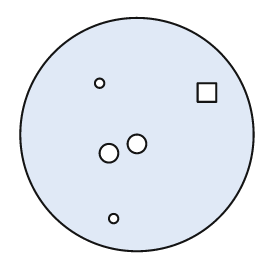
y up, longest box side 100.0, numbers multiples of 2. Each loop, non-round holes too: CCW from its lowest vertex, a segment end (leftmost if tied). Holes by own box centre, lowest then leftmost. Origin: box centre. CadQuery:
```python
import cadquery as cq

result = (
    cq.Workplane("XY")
    .moveTo(0.0, 0.0)
    .circle(50.0)
    .moveTo(-10.0, -36.0)
    .circle(2.0)
    .moveTo(-12.0, -8.0)
    .circle(4.0)
    .moveTo(0.0, -4.0)
    .circle(4.0)
    .moveTo(26.0, 14.0)
    .lineTo(34.0, 14.0)
    .lineTo(34.0, 22.0)
    .lineTo(26.0, 22.0)
    .close()
    .moveTo(-16.0, 22.0)
    .circle(2.0)
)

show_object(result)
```